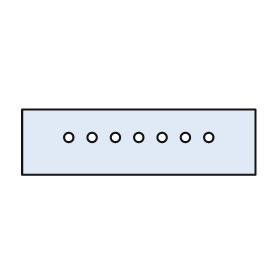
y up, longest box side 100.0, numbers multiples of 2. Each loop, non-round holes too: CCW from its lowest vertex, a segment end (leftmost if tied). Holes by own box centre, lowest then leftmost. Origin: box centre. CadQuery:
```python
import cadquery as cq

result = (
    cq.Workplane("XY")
    .moveTo(-50.0, -14.0)
    .lineTo(50.0, -14.0)
    .lineTo(50.0, 14.0)
    .lineTo(-50.0, 14.0)
    .close()
    .moveTo(-30.0, 2.0)
    .circle(2.0)
    .moveTo(-20.0, 2.0)
    .circle(2.0)
    .moveTo(-10.0, 2.0)
    .circle(2.0)
    .moveTo(0.0, 2.0)
    .circle(2.0)
    .moveTo(10.0, 2.0)
    .circle(2.0)
    .moveTo(20.0, 2.0)
    .circle(2.0)
    .moveTo(30.0, 2.0)
    .circle(2.0)
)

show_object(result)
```